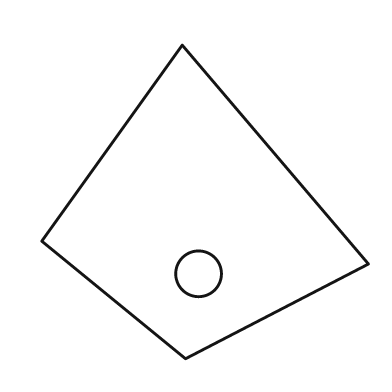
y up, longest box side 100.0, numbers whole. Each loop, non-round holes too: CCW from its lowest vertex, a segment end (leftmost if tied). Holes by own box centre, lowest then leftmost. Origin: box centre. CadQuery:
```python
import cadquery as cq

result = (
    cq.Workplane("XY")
    .moveTo(-6.0, -48.0)
    .lineTo(50.0, -19.0)
    .lineTo(-7.0, 48.0)
    .lineTo(-50.0, -12.0)
    .close()
    .moveTo(-2.0, -22.0)
    .circle(7.0)
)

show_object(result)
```